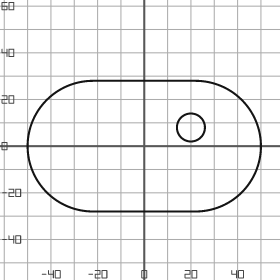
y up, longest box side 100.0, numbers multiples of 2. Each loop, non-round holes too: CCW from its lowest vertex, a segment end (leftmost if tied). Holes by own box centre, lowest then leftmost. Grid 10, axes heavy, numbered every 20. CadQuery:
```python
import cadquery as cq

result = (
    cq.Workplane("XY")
    .moveTo(-22.0, -28.0)
    .lineTo(22.0, -28.0)
    .threePointArc((50.0, 0.0), (22.0, 28.0))
    .lineTo(-22.0, 28.0)
    .threePointArc((-50.0, 0.0), (-22.0, -28.0))
    .close()
    .moveTo(20.0, 8.0)
    .circle(6.0)
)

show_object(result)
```